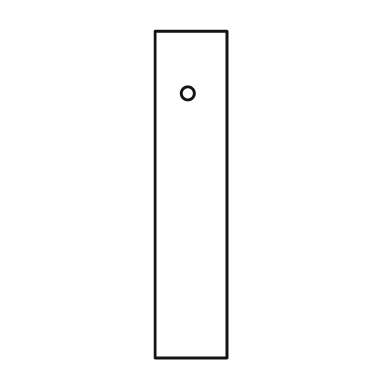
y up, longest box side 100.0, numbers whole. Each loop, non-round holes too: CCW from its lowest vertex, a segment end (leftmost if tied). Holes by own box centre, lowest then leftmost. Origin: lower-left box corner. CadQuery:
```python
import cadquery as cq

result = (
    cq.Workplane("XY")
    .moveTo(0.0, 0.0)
    .lineTo(22.0, 0.0)
    .lineTo(22.0, 100.0)
    .lineTo(0.0, 100.0)
    .close()
    .moveTo(10.0, 81.0)
    .circle(2.0)
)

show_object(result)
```